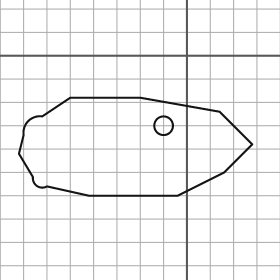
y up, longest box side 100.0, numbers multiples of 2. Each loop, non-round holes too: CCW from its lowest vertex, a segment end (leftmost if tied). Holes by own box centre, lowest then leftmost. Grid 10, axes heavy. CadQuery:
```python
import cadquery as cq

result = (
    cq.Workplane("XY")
    .moveTo(-42.0, -60.0)
    .lineTo(-4.0, -60.0)
    .lineTo(16.0, -50.0)
    .lineTo(28.0, -38.0)
    .lineTo(14.0, -24.0)
    .lineTo(-20.0, -18.0)
    .lineTo(-50.0, -18.0)
    .lineTo(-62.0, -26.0)
    .threePointArc((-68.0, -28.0), (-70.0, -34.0))
    .lineTo(-72.0, -42.0)
    .lineTo(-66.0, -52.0)
    .threePointArc((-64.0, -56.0), (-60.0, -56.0))
    .close()
    .moveTo(-10.0, -30.0)
    .circle(4.0)
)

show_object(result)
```